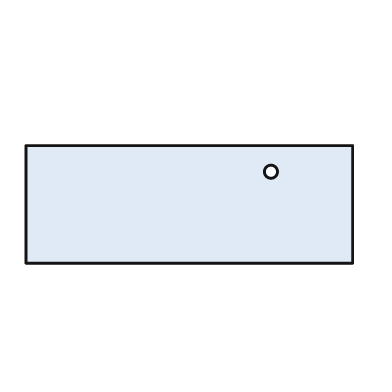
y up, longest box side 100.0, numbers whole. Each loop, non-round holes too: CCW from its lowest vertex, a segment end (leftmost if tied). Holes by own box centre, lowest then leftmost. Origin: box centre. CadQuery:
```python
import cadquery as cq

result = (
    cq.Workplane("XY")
    .moveTo(-50.0, -18.0)
    .lineTo(50.0, -18.0)
    .lineTo(50.0, 18.0)
    .lineTo(-50.0, 18.0)
    .close()
    .moveTo(25.0, 10.0)
    .circle(2.0)
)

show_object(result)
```